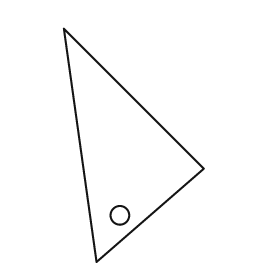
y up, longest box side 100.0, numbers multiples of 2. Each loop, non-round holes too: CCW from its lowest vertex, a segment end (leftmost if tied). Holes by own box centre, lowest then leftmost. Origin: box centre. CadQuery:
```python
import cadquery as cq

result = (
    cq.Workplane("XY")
    .moveTo(-16.0, -50.0)
    .lineTo(30.0, -10.0)
    .lineTo(-30.0, 50.0)
    .close()
    .moveTo(-6.0, -30.0)
    .circle(4.0)
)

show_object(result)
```